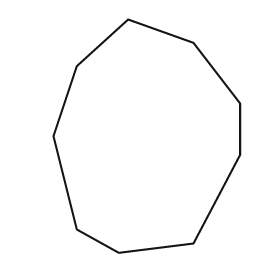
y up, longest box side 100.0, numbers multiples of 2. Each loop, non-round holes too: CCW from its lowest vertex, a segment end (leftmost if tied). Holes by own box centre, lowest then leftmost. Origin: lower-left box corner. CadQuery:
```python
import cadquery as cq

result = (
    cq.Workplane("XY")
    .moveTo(28.0, 0.0)
    .lineTo(60.0, 4.0)
    .lineTo(80.0, 42.0)
    .lineTo(80.0, 64.0)
    .lineTo(60.0, 90.0)
    .lineTo(32.0, 100.0)
    .lineTo(10.0, 80.0)
    .lineTo(0.0, 50.0)
    .lineTo(10.0, 10.0)
    .close()
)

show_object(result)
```